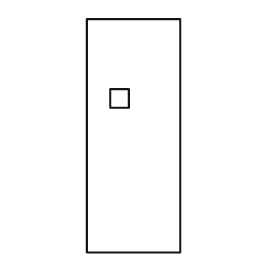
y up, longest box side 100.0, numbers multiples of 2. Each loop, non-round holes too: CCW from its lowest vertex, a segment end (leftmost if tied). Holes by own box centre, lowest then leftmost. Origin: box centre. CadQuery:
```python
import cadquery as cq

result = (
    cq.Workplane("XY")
    .moveTo(-20.0, -50.0)
    .lineTo(20.0, -50.0)
    .lineTo(20.0, 50.0)
    .lineTo(-20.0, 50.0)
    .close()
    .moveTo(-10.0, 12.0)
    .lineTo(-2.0, 12.0)
    .lineTo(-2.0, 20.0)
    .lineTo(-10.0, 20.0)
    .close()
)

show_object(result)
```